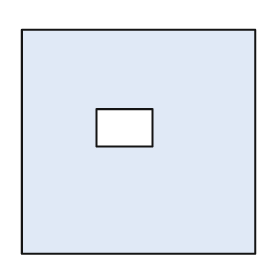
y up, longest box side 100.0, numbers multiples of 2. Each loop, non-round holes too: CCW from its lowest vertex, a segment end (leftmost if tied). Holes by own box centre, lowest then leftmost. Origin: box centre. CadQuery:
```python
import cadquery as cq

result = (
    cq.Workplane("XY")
    .moveTo(-50.0, -48.0)
    .lineTo(50.0, -48.0)
    .lineTo(50.0, 48.0)
    .lineTo(-50.0, 48.0)
    .close()
    .moveTo(-18.0, -2.0)
    .lineTo(6.0, -2.0)
    .lineTo(6.0, 14.0)
    .lineTo(-18.0, 14.0)
    .close()
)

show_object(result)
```